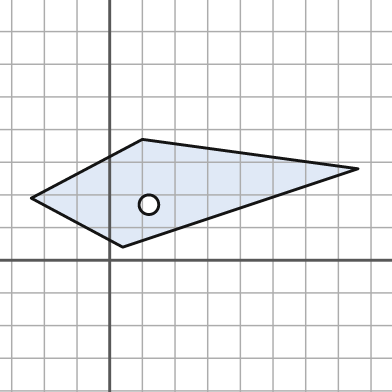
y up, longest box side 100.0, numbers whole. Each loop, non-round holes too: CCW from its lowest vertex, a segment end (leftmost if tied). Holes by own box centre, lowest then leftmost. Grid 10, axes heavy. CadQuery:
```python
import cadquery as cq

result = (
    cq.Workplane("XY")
    .moveTo(4.0, 4.0)
    .lineTo(76.0, 28.0)
    .lineTo(10.0, 37.0)
    .lineTo(-24.0, 19.0)
    .close()
    .moveTo(12.0, 17.0)
    .circle(3.0)
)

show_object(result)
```